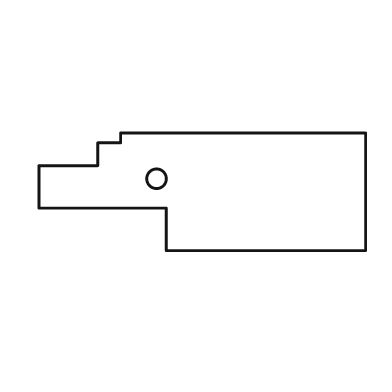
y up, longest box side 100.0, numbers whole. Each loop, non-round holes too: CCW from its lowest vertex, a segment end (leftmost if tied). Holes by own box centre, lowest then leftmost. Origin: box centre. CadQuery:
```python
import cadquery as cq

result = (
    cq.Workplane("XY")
    .moveTo(-11.0, -18.0)
    .lineTo(50.0, -18.0)
    .lineTo(50.0, 18.0)
    .lineTo(-25.0, 18.0)
    .lineTo(-25.0, 15.0)
    .lineTo(-32.0, 15.0)
    .lineTo(-32.0, 8.0)
    .lineTo(-50.0, 8.0)
    .lineTo(-50.0, -5.0)
    .lineTo(-11.0, -5.0)
    .close()
    .moveTo(-14.0, 4.0)
    .circle(3.0)
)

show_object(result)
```